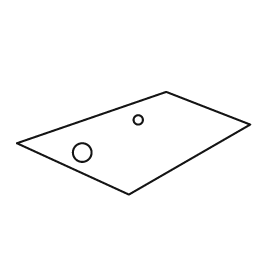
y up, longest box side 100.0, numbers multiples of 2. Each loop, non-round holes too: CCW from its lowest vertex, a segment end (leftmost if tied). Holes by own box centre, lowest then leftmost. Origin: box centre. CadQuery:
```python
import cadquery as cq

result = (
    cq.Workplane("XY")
    .moveTo(-2.0, -22.0)
    .lineTo(50.0, 8.0)
    .lineTo(14.0, 22.0)
    .lineTo(-50.0, 0.0)
    .close()
    .moveTo(-22.0, -4.0)
    .circle(4.0)
    .moveTo(2.0, 10.0)
    .circle(2.0)
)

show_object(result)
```